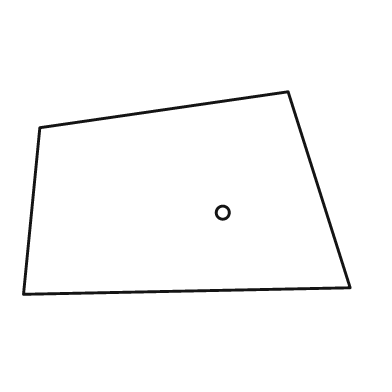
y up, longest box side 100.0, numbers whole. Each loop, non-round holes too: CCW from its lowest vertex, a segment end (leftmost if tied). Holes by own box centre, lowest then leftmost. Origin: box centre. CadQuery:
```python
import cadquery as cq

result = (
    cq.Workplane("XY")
    .moveTo(-50.0, -31.0)
    .lineTo(50.0, -29.0)
    .lineTo(31.0, 31.0)
    .lineTo(-45.0, 20.0)
    .close()
    .moveTo(11.0, -6.0)
    .circle(2.0)
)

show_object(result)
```